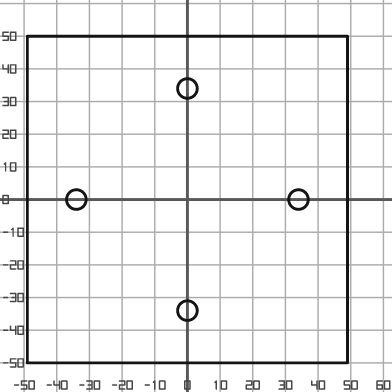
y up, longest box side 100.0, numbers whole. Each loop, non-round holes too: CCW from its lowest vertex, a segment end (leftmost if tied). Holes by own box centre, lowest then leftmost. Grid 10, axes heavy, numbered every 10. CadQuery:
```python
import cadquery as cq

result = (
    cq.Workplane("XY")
    .moveTo(-49.0, -50.0)
    .lineTo(49.0, -50.0)
    .lineTo(49.0, 50.0)
    .lineTo(-49.0, 50.0)
    .close()
    .moveTo(0.0, -34.0)
    .circle(3.0)
    .moveTo(-34.0, 0.0)
    .circle(3.0)
    .moveTo(34.0, 0.0)
    .circle(3.0)
    .moveTo(0.0, 34.0)
    .circle(3.0)
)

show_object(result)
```